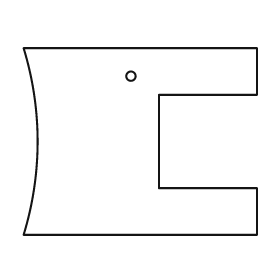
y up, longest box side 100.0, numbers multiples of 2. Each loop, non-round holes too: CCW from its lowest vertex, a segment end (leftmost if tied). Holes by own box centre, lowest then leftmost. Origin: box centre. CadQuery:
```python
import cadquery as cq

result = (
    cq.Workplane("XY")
    .moveTo(-50.0, -40.0)
    .lineTo(50.0, -40.0)
    .lineTo(50.0, -20.0)
    .lineTo(8.0, -20.0)
    .lineTo(8.0, 20.0)
    .lineTo(50.0, 20.0)
    .lineTo(50.0, 40.0)
    .lineTo(-50.0, 40.0)
    .threePointArc((-44.0, 0.0), (-50.0, -40.0))
    .close()
    .moveTo(-4.0, 28.0)
    .circle(2.0)
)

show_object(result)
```